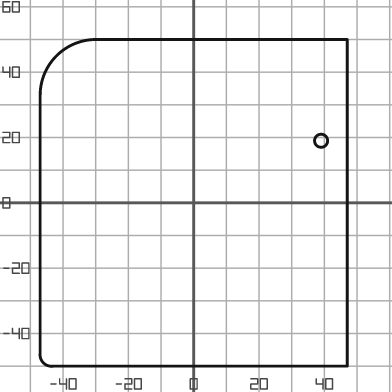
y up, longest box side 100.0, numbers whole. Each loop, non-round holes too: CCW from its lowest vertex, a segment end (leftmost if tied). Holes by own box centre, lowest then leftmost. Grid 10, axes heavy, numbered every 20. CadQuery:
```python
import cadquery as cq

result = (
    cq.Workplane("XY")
    .moveTo(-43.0, -50.0)
    .lineTo(47.0, -50.0)
    .lineTo(47.0, 50.0)
    .lineTo(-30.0, 50.0)
    .threePointArc((-42.0, 45.0), (-47.0, 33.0))
    .lineTo(-47.0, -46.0)
    .threePointArc((-46.0, -49.0), (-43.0, -50.0))
    .close()
    .moveTo(39.0, 19.0)
    .circle(2.0)
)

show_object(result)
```